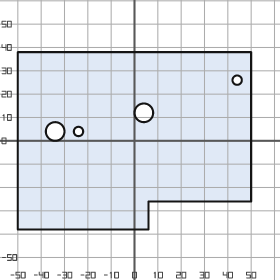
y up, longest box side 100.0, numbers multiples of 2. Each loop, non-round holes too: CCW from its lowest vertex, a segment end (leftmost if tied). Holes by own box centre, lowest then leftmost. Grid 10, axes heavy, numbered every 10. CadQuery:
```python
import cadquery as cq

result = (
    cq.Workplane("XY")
    .moveTo(-50.0, -38.0)
    .lineTo(6.0, -38.0)
    .lineTo(6.0, -26.0)
    .lineTo(50.0, -26.0)
    .lineTo(50.0, 38.0)
    .lineTo(-50.0, 38.0)
    .close()
    .moveTo(-34.0, 4.0)
    .circle(4.0)
    .moveTo(-24.0, 4.0)
    .circle(2.0)
    .moveTo(4.0, 12.0)
    .circle(4.0)
    .moveTo(44.0, 26.0)
    .circle(2.0)
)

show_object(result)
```